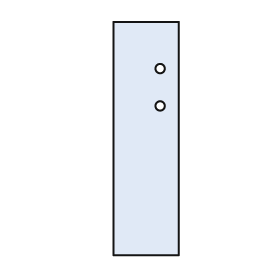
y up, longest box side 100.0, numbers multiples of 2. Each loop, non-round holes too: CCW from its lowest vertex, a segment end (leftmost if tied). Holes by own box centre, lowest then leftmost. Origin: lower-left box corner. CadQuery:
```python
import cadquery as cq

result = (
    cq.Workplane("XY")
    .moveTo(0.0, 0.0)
    .lineTo(28.0, 0.0)
    .lineTo(28.0, 100.0)
    .lineTo(0.0, 100.0)
    .close()
    .moveTo(20.0, 64.0)
    .circle(2.0)
    .moveTo(20.0, 80.0)
    .circle(2.0)
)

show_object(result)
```